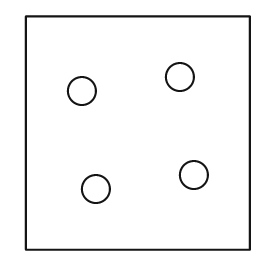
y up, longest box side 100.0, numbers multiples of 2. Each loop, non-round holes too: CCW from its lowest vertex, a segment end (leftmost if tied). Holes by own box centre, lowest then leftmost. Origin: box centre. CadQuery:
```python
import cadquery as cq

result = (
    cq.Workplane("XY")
    .moveTo(-48.0, -50.0)
    .lineTo(48.0, -50.0)
    .lineTo(48.0, 50.0)
    .lineTo(-48.0, 50.0)
    .close()
    .moveTo(-18.0, -24.0)
    .circle(6.0)
    .moveTo(24.0, -18.0)
    .circle(6.0)
    .moveTo(-24.0, 18.0)
    .circle(6.0)
    .moveTo(18.0, 24.0)
    .circle(6.0)
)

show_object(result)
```